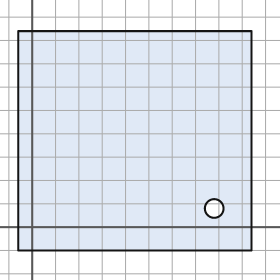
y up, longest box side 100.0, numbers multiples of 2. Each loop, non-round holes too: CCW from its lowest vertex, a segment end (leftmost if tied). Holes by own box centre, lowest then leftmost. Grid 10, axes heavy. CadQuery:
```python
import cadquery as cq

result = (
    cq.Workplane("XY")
    .moveTo(-6.0, -10.0)
    .lineTo(94.0, -10.0)
    .lineTo(94.0, 84.0)
    .lineTo(-6.0, 84.0)
    .close()
    .moveTo(78.0, 8.0)
    .circle(4.0)
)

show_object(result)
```